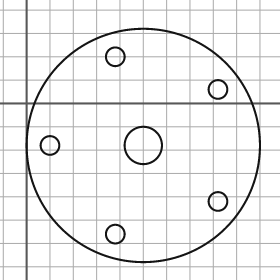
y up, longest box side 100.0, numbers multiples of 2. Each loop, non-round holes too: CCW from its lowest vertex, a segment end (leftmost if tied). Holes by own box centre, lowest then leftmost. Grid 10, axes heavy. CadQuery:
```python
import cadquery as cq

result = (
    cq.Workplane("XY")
    .moveTo(50.0, -18.0)
    .circle(50.0)
    .moveTo(38.0, -56.0)
    .circle(4.0)
    .moveTo(82.0, -42.0)
    .circle(4.0)
    .moveTo(10.0, -18.0)
    .circle(4.0)
    .moveTo(50.0, -18.0)
    .circle(8.0)
    .moveTo(82.0, 6.0)
    .circle(4.0)
    .moveTo(38.0, 20.0)
    .circle(4.0)
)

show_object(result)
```